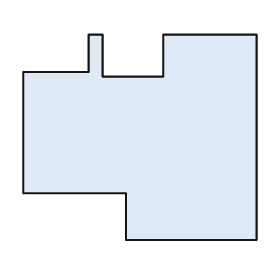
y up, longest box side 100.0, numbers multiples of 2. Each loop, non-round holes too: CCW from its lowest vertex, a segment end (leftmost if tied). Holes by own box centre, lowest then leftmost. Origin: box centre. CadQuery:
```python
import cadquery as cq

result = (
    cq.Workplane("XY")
    .moveTo(-6.0, -44.0)
    .lineTo(50.0, -44.0)
    .lineTo(50.0, 44.0)
    .lineTo(10.0, 44.0)
    .lineTo(10.0, 26.0)
    .lineTo(-16.0, 26.0)
    .lineTo(-16.0, 44.0)
    .lineTo(-22.0, 44.0)
    .lineTo(-22.0, 28.0)
    .lineTo(-50.0, 28.0)
    .lineTo(-50.0, -24.0)
    .lineTo(-6.0, -24.0)
    .close()
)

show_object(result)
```